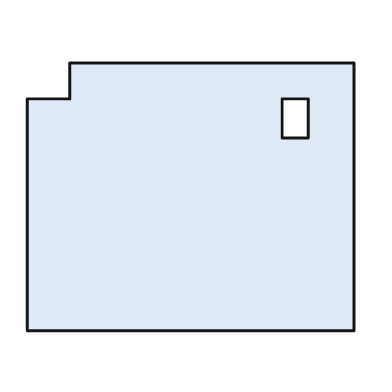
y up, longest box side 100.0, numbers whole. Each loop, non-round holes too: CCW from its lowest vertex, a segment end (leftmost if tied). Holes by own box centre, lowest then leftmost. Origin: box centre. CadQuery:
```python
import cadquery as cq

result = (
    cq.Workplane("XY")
    .moveTo(-50.0, -41.0)
    .lineTo(50.0, -41.0)
    .lineTo(50.0, 41.0)
    .lineTo(-37.0, 41.0)
    .lineTo(-37.0, 30.0)
    .lineTo(-50.0, 30.0)
    .close()
    .moveTo(28.0, 18.0)
    .lineTo(36.0, 18.0)
    .lineTo(36.0, 30.0)
    .lineTo(28.0, 30.0)
    .close()
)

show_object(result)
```